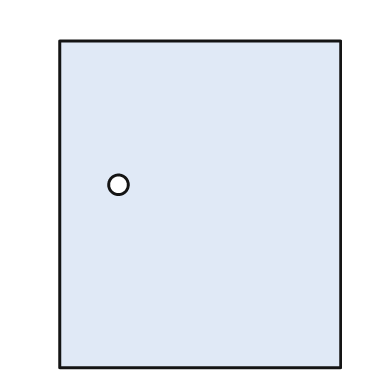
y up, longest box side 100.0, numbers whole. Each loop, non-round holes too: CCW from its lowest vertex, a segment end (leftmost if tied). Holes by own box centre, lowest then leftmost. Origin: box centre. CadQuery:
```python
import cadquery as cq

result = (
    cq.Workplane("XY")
    .moveTo(-43.0, -50.0)
    .lineTo(43.0, -50.0)
    .lineTo(43.0, 50.0)
    .lineTo(-43.0, 50.0)
    .close()
    .moveTo(-25.0, 6.0)
    .circle(3.0)
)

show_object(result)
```